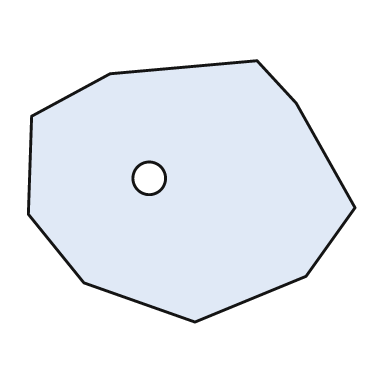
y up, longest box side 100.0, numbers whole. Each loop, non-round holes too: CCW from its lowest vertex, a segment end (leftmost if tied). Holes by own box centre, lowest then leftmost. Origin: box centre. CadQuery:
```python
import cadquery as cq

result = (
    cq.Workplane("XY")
    .moveTo(1.0, -40.0)
    .lineTo(35.0, -26.0)
    .lineTo(50.0, -5.0)
    .lineTo(32.0, 27.0)
    .lineTo(20.0, 40.0)
    .lineTo(-25.0, 36.0)
    .lineTo(-49.0, 23.0)
    .lineTo(-50.0, -7.0)
    .lineTo(-33.0, -28.0)
    .close()
    .moveTo(-13.0, 4.0)
    .circle(5.0)
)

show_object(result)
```